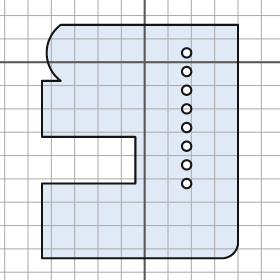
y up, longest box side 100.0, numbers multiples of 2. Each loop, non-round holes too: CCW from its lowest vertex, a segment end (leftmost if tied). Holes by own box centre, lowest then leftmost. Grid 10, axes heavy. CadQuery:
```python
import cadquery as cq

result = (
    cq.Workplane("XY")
    .moveTo(-44.0, -84.0)
    .lineTo(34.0, -84.0)
    .threePointArc((38.0, -82.0), (40.0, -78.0))
    .lineTo(40.0, 16.0)
    .lineTo(-36.0, 16.0)
    .threePointArc((-42.0, 4.0), (-36.0, -8.0))
    .lineTo(-44.0, -8.0)
    .lineTo(-44.0, -32.0)
    .lineTo(-4.0, -32.0)
    .lineTo(-4.0, -52.0)
    .lineTo(-44.0, -52.0)
    .close()
    .moveTo(18.0, -52.0)
    .circle(2.0)
    .moveTo(18.0, -44.0)
    .circle(2.0)
    .moveTo(18.0, -36.0)
    .circle(2.0)
    .moveTo(18.0, -28.0)
    .circle(2.0)
    .moveTo(18.0, -20.0)
    .circle(2.0)
    .moveTo(18.0, -12.0)
    .circle(2.0)
    .moveTo(18.0, -4.0)
    .circle(2.0)
    .moveTo(18.0, 4.0)
    .circle(2.0)
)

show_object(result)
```